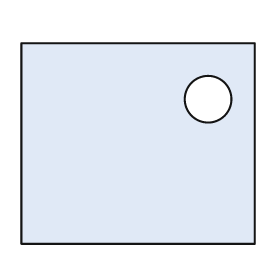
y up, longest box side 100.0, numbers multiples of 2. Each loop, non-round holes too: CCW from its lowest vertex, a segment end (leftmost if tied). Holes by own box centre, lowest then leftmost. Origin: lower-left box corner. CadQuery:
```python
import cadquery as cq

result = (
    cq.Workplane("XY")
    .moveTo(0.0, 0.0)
    .lineTo(100.0, 0.0)
    .lineTo(100.0, 86.0)
    .lineTo(0.0, 86.0)
    .close()
    .moveTo(80.0, 62.0)
    .circle(10.0)
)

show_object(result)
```